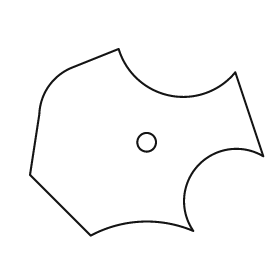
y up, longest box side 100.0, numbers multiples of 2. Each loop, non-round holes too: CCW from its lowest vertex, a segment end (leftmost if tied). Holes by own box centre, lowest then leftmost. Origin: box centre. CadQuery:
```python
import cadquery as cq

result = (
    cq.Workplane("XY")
    .moveTo(-24.0, -40.0)
    .threePointArc((-2.0, -34.0), (20.0, -38.0))
    .threePointArc((22.0, -10.0), (50.0, -6.0))
    .lineTo(38.0, 30.0)
    .threePointArc((10.0, 20.0), (-12.0, 40.0))
    .lineTo(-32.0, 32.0)
    .threePointArc((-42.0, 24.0), (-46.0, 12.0))
    .lineTo(-50.0, -14.0)
    .close()
    .moveTo(0.0, 0.0)
    .circle(4.0)
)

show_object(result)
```